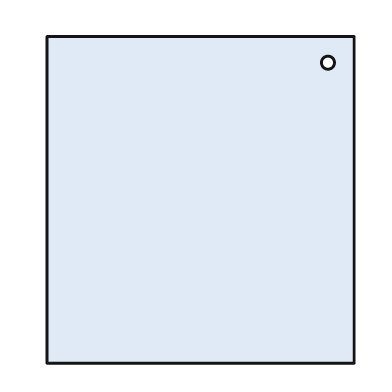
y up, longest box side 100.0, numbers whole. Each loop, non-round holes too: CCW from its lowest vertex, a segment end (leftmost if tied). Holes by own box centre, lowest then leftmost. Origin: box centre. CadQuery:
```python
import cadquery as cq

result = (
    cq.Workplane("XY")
    .moveTo(-47.0, -50.0)
    .lineTo(47.0, -50.0)
    .lineTo(47.0, 50.0)
    .lineTo(-47.0, 50.0)
    .close()
    .moveTo(39.0, 42.0)
    .circle(2.0)
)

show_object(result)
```